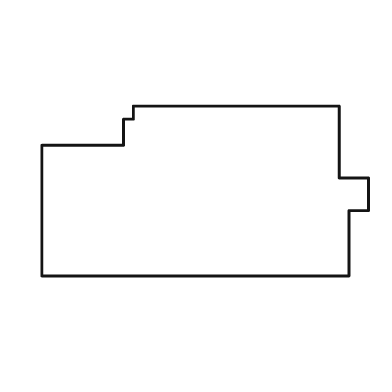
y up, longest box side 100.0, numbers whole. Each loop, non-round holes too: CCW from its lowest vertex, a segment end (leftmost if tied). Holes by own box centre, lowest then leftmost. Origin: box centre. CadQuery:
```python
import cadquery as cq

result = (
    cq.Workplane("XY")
    .moveTo(-50.0, -26.0)
    .lineTo(44.0, -26.0)
    .lineTo(44.0, -6.0)
    .lineTo(50.0, -6.0)
    .lineTo(50.0, 4.0)
    .lineTo(41.0, 4.0)
    .lineTo(41.0, 26.0)
    .lineTo(-22.0, 26.0)
    .lineTo(-22.0, 22.0)
    .lineTo(-25.0, 22.0)
    .lineTo(-25.0, 14.0)
    .lineTo(-50.0, 14.0)
    .close()
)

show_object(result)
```